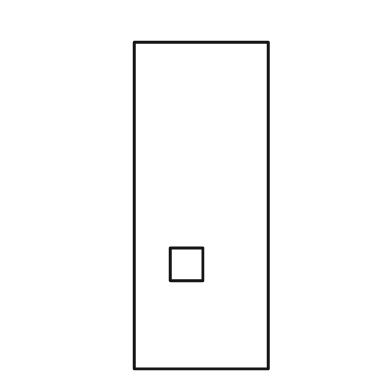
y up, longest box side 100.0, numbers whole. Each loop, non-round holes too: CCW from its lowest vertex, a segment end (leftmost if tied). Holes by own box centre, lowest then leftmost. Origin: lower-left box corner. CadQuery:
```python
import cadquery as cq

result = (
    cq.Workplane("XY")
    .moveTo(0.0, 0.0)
    .lineTo(41.0, 0.0)
    .lineTo(41.0, 100.0)
    .lineTo(0.0, 100.0)
    .close()
    .moveTo(11.0, 27.0)
    .lineTo(21.0, 27.0)
    .lineTo(21.0, 37.0)
    .lineTo(11.0, 37.0)
    .close()
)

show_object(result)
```